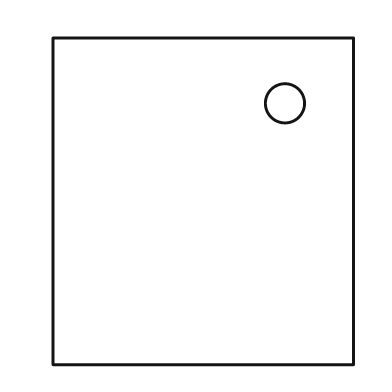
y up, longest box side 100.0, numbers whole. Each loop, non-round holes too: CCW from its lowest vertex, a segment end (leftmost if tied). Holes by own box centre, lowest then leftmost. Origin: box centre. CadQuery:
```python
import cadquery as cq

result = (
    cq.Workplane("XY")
    .moveTo(-46.0, -50.0)
    .lineTo(46.0, -50.0)
    .lineTo(46.0, 50.0)
    .lineTo(-46.0, 50.0)
    .close()
    .moveTo(25.0, 30.0)
    .circle(6.0)
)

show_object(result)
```